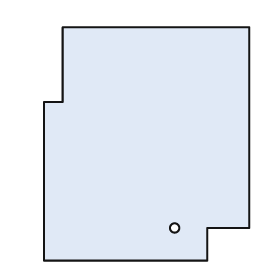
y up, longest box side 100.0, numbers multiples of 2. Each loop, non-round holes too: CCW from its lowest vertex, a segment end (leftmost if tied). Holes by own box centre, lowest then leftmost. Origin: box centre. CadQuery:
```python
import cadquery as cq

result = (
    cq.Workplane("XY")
    .moveTo(-44.0, -50.0)
    .lineTo(26.0, -50.0)
    .lineTo(26.0, -36.0)
    .lineTo(44.0, -36.0)
    .lineTo(44.0, 50.0)
    .lineTo(-36.0, 50.0)
    .lineTo(-36.0, 18.0)
    .lineTo(-44.0, 18.0)
    .close()
    .moveTo(12.0, -36.0)
    .circle(2.0)
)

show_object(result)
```